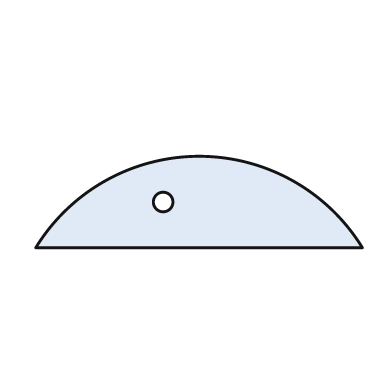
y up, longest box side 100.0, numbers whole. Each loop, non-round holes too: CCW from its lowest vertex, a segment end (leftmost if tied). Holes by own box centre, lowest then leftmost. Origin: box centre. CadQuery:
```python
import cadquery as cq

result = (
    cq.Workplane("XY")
    .moveTo(-50.0, -14.0)
    .lineTo(50.0, -14.0)
    .threePointArc((0.0, 14.0), (-50.0, -14.0))
    .close()
    .moveTo(-11.0, 0.0)
    .circle(3.0)
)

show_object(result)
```